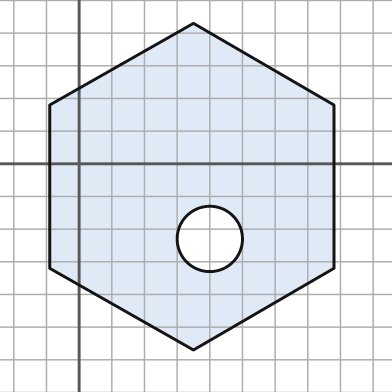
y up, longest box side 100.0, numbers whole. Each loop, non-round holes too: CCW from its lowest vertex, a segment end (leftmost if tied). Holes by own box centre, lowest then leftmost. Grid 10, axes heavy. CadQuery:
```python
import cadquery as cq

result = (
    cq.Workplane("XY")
    .moveTo(35.0, -57.0)
    .lineTo(78.0, -32.0)
    .lineTo(78.0, 18.0)
    .lineTo(35.0, 43.0)
    .lineTo(-9.0, 18.0)
    .lineTo(-9.0, -32.0)
    .close()
    .moveTo(40.0, -23.0)
    .circle(10.0)
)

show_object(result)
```